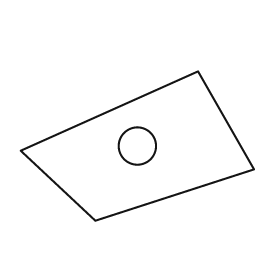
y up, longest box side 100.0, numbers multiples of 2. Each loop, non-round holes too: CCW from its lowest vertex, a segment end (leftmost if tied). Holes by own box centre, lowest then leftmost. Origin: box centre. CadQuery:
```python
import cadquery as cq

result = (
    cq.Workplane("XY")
    .moveTo(-18.0, -32.0)
    .lineTo(50.0, -10.0)
    .lineTo(26.0, 32.0)
    .lineTo(-50.0, -2.0)
    .close()
    .moveTo(0.0, 0.0)
    .circle(8.0)
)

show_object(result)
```